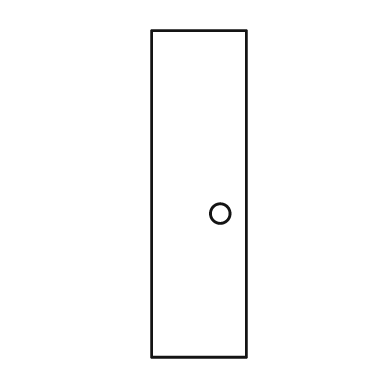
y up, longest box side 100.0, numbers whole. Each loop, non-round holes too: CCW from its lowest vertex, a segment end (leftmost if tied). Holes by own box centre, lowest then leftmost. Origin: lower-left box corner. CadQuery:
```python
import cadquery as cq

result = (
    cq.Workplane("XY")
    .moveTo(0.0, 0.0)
    .lineTo(29.0, 0.0)
    .lineTo(29.0, 100.0)
    .lineTo(0.0, 100.0)
    .close()
    .moveTo(21.0, 44.0)
    .circle(3.0)
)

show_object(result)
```